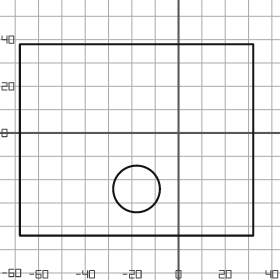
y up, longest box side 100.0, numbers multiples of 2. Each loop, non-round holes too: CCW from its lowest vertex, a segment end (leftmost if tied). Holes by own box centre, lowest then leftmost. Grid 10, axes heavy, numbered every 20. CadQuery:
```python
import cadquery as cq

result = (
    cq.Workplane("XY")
    .moveTo(-68.0, -44.0)
    .lineTo(32.0, -44.0)
    .lineTo(32.0, 38.0)
    .lineTo(-68.0, 38.0)
    .close()
    .moveTo(-18.0, -24.0)
    .circle(10.0)
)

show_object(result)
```